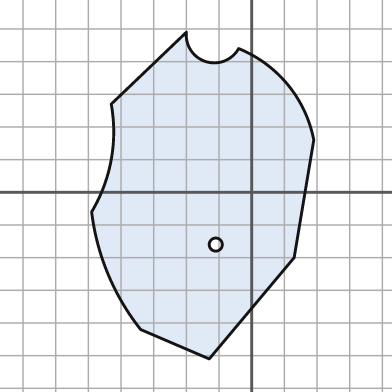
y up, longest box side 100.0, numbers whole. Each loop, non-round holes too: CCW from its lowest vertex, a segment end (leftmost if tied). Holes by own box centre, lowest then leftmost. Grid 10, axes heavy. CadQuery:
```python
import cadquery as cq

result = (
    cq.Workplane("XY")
    .moveTo(-13.0, -51.0)
    .lineTo(13.0, -20.0)
    .lineTo(19.0, 16.0)
    .threePointArc((11.0, 33.0), (-4.0, 44.0))
    .threePointArc((-14.0, 40.0), (-20.0, 49.0))
    .lineTo(-43.0, 27.0)
    .threePointArc((-43.0, 10.0), (-49.0, -6.0))
    .threePointArc((-44.0, -25.0), (-34.0, -42.0))
    .close()
    .moveTo(-11.0, -16.0)
    .circle(2.0)
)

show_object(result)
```